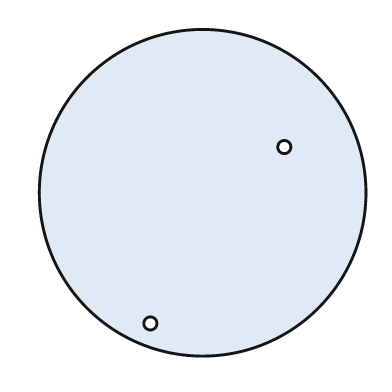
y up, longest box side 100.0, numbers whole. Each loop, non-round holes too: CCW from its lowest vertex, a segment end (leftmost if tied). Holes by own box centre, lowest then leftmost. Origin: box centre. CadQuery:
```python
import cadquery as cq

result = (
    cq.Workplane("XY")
    .moveTo(0.0, 0.0)
    .circle(50.0)
    .moveTo(-16.0, -40.0)
    .circle(2.0)
    .moveTo(25.0, 14.0)
    .circle(2.0)
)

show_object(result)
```